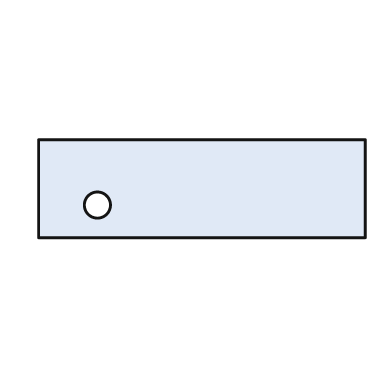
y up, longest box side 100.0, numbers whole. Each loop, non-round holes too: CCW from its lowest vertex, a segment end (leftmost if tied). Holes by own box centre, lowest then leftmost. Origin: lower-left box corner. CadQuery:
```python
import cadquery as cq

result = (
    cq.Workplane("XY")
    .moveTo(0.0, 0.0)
    .lineTo(100.0, 0.0)
    .lineTo(100.0, 30.0)
    .lineTo(0.0, 30.0)
    .close()
    .moveTo(18.0, 10.0)
    .circle(4.0)
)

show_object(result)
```